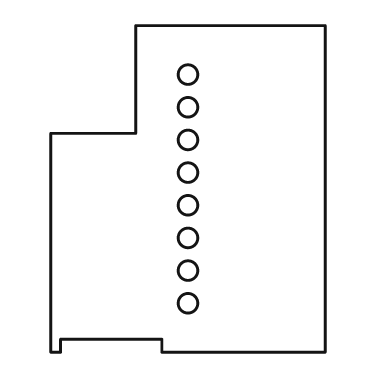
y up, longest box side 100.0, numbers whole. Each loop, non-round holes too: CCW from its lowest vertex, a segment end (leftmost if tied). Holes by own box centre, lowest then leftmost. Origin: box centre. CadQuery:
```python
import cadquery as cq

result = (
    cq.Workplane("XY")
    .moveTo(-42.0, -50.0)
    .lineTo(-39.0, -50.0)
    .lineTo(-39.0, -46.0)
    .lineTo(-8.0, -46.0)
    .lineTo(-8.0, -50.0)
    .lineTo(42.0, -50.0)
    .lineTo(42.0, 50.0)
    .lineTo(-16.0, 50.0)
    .lineTo(-16.0, 17.0)
    .lineTo(-42.0, 17.0)
    .close()
    .moveTo(0.0, -35.0)
    .circle(3.0)
    .moveTo(0.0, -25.0)
    .circle(3.0)
    .moveTo(0.0, -15.0)
    .circle(3.0)
    .moveTo(0.0, -5.0)
    .circle(3.0)
    .moveTo(0.0, 5.0)
    .circle(3.0)
    .moveTo(0.0, 15.0)
    .circle(3.0)
    .moveTo(0.0, 25.0)
    .circle(3.0)
    .moveTo(0.0, 35.0)
    .circle(3.0)
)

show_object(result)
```